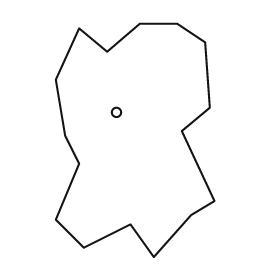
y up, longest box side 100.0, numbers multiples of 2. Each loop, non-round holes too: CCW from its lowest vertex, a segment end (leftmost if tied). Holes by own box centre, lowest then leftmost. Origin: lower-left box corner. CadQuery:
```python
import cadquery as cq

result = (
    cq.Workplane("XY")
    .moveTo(42.0, 0.0)
    .lineTo(58.0, 18.0)
    .lineTo(68.0, 24.0)
    .lineTo(54.0, 54.0)
    .lineTo(66.0, 64.0)
    .lineTo(64.0, 92.0)
    .lineTo(52.0, 100.0)
    .lineTo(36.0, 100.0)
    .lineTo(22.0, 88.0)
    .lineTo(10.0, 98.0)
    .lineTo(0.0, 76.0)
    .lineTo(4.0, 52.0)
    .lineTo(10.0, 40.0)
    .lineTo(0.0, 16.0)
    .lineTo(12.0, 4.0)
    .lineTo(32.0, 14.0)
    .close()
    .moveTo(26.0, 62.0)
    .circle(2.0)
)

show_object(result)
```